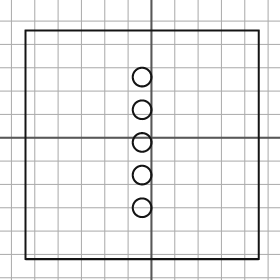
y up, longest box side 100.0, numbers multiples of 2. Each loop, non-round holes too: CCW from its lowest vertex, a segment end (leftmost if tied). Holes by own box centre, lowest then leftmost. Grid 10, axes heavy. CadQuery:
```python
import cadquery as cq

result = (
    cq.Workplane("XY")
    .moveTo(-54.0, -52.0)
    .lineTo(46.0, -52.0)
    .lineTo(46.0, 46.0)
    .lineTo(-54.0, 46.0)
    .close()
    .moveTo(-4.0, -30.0)
    .circle(4.0)
    .moveTo(-4.0, -16.0)
    .circle(4.0)
    .moveTo(-4.0, -2.0)
    .circle(4.0)
    .moveTo(-4.0, 12.0)
    .circle(4.0)
    .moveTo(-4.0, 26.0)
    .circle(4.0)
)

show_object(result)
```